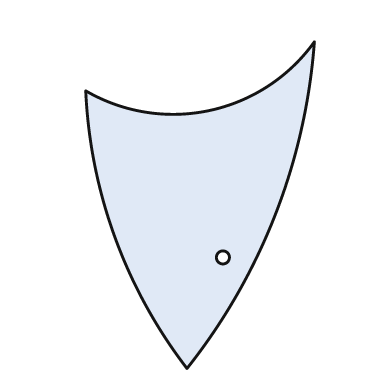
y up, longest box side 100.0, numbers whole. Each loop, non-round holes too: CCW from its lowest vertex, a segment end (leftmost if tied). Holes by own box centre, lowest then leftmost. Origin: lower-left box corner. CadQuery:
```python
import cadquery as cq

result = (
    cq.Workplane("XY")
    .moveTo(31.0, 0.0)
    .threePointArc((58.0, 47.0), (70.0, 100.0))
    .threePointArc((38.0, 79.0), (0.0, 85.0))
    .threePointArc((9.0, 40.0), (31.0, 0.0))
    .close()
    .moveTo(42.0, 34.0)
    .circle(2.0)
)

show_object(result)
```